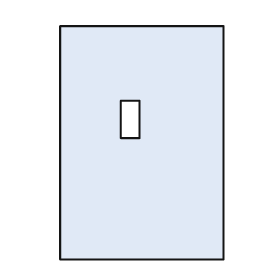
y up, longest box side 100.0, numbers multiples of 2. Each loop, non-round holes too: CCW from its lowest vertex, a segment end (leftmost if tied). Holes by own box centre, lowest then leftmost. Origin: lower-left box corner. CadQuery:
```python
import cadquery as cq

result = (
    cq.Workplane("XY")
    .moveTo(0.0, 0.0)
    .lineTo(70.0, 0.0)
    .lineTo(70.0, 100.0)
    .lineTo(0.0, 100.0)
    .close()
    .moveTo(26.0, 52.0)
    .lineTo(34.0, 52.0)
    .lineTo(34.0, 68.0)
    .lineTo(26.0, 68.0)
    .close()
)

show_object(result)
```